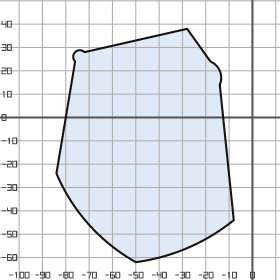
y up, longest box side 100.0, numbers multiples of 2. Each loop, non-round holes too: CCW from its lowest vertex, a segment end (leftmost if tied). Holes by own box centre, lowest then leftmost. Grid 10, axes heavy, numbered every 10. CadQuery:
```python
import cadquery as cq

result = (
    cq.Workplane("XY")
    .moveTo(-50.0, -62.0)
    .threePointArc((-28.0, -56.0), (-8.0, -44.0))
    .lineTo(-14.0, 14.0)
    .threePointArc((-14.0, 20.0), (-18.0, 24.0))
    .lineTo(-28.0, 38.0)
    .lineTo(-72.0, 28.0)
    .threePointArc((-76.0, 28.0), (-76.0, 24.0))
    .lineTo(-84.0, -24.0)
    .threePointArc((-70.0, -46.0), (-50.0, -62.0))
    .close()
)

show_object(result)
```